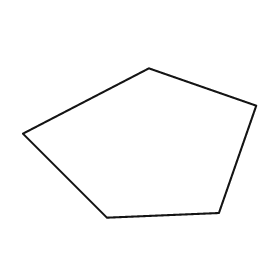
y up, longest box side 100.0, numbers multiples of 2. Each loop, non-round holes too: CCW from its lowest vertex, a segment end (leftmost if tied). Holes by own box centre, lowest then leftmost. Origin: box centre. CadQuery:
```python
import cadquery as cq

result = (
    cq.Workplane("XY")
    .moveTo(-14.0, -32.0)
    .lineTo(34.0, -30.0)
    .lineTo(50.0, 16.0)
    .lineTo(4.0, 32.0)
    .lineTo(-50.0, 4.0)
    .close()
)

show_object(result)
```